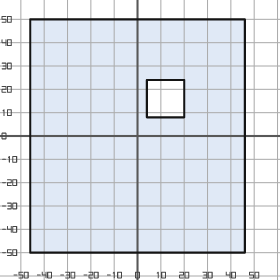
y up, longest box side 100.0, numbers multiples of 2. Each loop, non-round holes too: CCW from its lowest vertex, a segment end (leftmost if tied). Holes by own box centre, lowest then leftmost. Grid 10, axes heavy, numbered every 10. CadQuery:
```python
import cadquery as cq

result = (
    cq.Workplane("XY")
    .moveTo(-46.0, -50.0)
    .lineTo(46.0, -50.0)
    .lineTo(46.0, 50.0)
    .lineTo(-46.0, 50.0)
    .close()
    .moveTo(4.0, 8.0)
    .lineTo(20.0, 8.0)
    .lineTo(20.0, 24.0)
    .lineTo(4.0, 24.0)
    .close()
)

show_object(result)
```